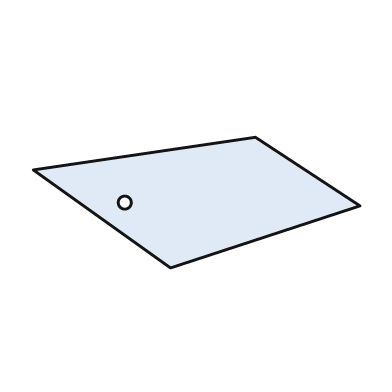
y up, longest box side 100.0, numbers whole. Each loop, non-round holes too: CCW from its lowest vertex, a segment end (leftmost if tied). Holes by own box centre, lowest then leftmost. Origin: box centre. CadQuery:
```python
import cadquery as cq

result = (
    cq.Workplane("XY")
    .moveTo(-8.0, -20.0)
    .lineTo(50.0, -1.0)
    .lineTo(18.0, 20.0)
    .lineTo(-50.0, 10.0)
    .close()
    .moveTo(-22.0, 0.0)
    .circle(2.0)
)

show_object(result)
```